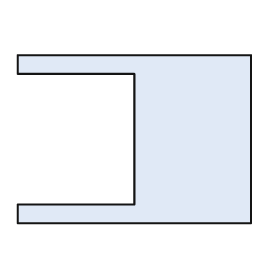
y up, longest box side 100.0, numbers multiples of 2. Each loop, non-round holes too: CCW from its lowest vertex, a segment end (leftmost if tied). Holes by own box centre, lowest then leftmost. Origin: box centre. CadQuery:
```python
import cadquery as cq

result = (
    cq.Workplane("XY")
    .moveTo(-50.0, -36.0)
    .lineTo(50.0, -36.0)
    .lineTo(50.0, 36.0)
    .lineTo(-50.0, 36.0)
    .lineTo(-50.0, 28.0)
    .lineTo(0.0, 28.0)
    .lineTo(0.0, -28.0)
    .lineTo(-50.0, -28.0)
    .close()
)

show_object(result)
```